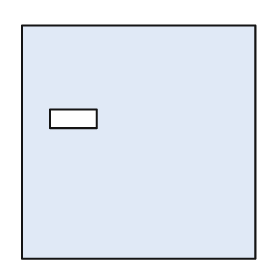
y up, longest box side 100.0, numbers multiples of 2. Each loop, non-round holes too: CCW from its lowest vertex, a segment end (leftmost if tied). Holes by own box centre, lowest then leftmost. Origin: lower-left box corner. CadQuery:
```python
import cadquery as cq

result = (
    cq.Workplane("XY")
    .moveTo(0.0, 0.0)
    .lineTo(100.0, 0.0)
    .lineTo(100.0, 100.0)
    .lineTo(0.0, 100.0)
    .close()
    .moveTo(12.0, 56.0)
    .lineTo(32.0, 56.0)
    .lineTo(32.0, 64.0)
    .lineTo(12.0, 64.0)
    .close()
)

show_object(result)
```